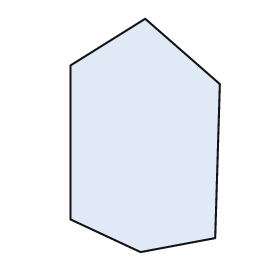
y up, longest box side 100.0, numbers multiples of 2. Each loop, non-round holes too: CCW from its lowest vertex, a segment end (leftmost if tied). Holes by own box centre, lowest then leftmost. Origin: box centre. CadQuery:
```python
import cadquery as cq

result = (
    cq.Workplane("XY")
    .moveTo(-2.0, -50.0)
    .lineTo(30.0, -44.0)
    .lineTo(32.0, 22.0)
    .lineTo(0.0, 50.0)
    .lineTo(-32.0, 30.0)
    .lineTo(-32.0, -36.0)
    .close()
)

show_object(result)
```